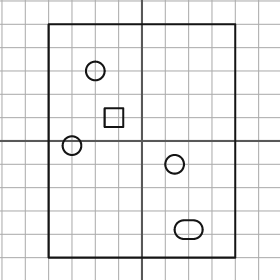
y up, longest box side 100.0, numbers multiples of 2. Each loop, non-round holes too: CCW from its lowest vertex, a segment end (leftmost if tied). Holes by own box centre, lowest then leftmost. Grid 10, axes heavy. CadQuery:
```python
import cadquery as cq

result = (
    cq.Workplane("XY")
    .moveTo(-40.0, -50.0)
    .lineTo(40.0, -50.0)
    .lineTo(40.0, 50.0)
    .lineTo(-40.0, 50.0)
    .close()
    .moveTo(18.0, -42.0)
    .lineTo(22.0, -42.0)
    .threePointArc((26.0, -38.0), (22.0, -34.0))
    .lineTo(18.0, -34.0)
    .threePointArc((14.0, -38.0), (18.0, -42.0))
    .close()
    .moveTo(14.0, -10.0)
    .circle(4.0)
    .moveTo(-30.0, -2.0)
    .circle(4.0)
    .moveTo(-16.0, 6.0)
    .lineTo(-8.0, 6.0)
    .lineTo(-8.0, 14.0)
    .lineTo(-16.0, 14.0)
    .close()
    .moveTo(-20.0, 30.0)
    .circle(4.0)
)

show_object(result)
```